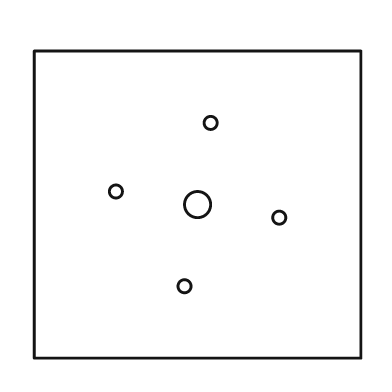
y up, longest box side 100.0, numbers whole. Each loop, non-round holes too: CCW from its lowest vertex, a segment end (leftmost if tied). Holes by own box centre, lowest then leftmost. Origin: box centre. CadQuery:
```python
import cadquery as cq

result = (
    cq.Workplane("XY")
    .moveTo(-50.0, -47.0)
    .lineTo(50.0, -47.0)
    .lineTo(50.0, 47.0)
    .lineTo(-50.0, 47.0)
    .close()
    .moveTo(-4.0, -25.0)
    .circle(2.0)
    .moveTo(25.0, -4.0)
    .circle(2.0)
    .moveTo(0.0, 0.0)
    .circle(4.0)
    .moveTo(-25.0, 4.0)
    .circle(2.0)
    .moveTo(4.0, 25.0)
    .circle(2.0)
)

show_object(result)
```